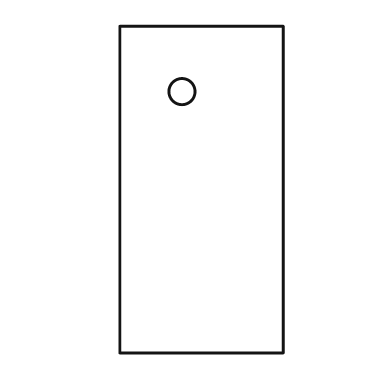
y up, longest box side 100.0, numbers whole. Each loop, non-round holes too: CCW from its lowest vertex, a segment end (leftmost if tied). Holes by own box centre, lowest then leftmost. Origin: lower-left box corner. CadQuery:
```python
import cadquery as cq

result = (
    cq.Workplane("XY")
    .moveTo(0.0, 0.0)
    .lineTo(50.0, 0.0)
    .lineTo(50.0, 100.0)
    .lineTo(0.0, 100.0)
    .close()
    .moveTo(19.0, 80.0)
    .circle(4.0)
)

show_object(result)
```